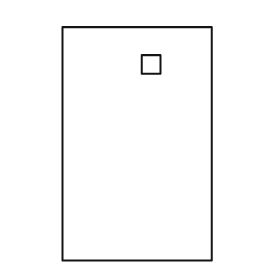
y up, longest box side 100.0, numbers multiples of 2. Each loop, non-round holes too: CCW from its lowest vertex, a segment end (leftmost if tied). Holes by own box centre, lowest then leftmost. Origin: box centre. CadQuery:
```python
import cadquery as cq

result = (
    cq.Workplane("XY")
    .moveTo(-32.0, -50.0)
    .lineTo(32.0, -50.0)
    .lineTo(32.0, 50.0)
    .lineTo(-32.0, 50.0)
    .close()
    .moveTo(2.0, 30.0)
    .lineTo(10.0, 30.0)
    .lineTo(10.0, 38.0)
    .lineTo(2.0, 38.0)
    .close()
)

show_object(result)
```